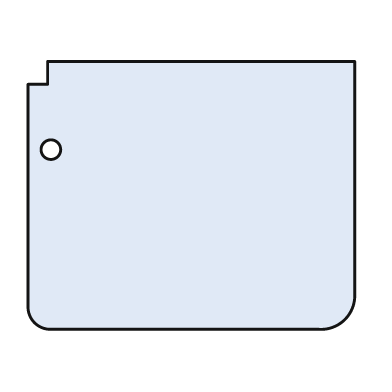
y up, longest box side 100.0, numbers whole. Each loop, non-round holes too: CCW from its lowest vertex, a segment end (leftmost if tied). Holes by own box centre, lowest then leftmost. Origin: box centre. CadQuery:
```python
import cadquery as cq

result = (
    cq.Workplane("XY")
    .moveTo(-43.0, -41.0)
    .lineTo(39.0, -41.0)
    .threePointArc((47.0, -38.0), (50.0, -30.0))
    .lineTo(50.0, 41.0)
    .lineTo(-44.0, 41.0)
    .lineTo(-44.0, 34.0)
    .lineTo(-50.0, 34.0)
    .lineTo(-50.0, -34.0)
    .threePointArc((-48.0, -39.0), (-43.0, -41.0))
    .close()
    .moveTo(-43.0, 14.0)
    .circle(3.0)
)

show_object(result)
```